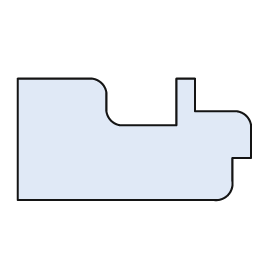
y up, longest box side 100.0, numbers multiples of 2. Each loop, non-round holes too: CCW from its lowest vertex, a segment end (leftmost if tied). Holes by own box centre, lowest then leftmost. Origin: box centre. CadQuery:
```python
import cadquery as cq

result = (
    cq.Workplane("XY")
    .moveTo(-50.0, -26.0)
    .lineTo(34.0, -26.0)
    .threePointArc((40.0, -24.0), (42.0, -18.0))
    .lineTo(42.0, -8.0)
    .lineTo(50.0, -8.0)
    .lineTo(50.0, 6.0)
    .threePointArc((48.0, 10.0), (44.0, 12.0))
    .lineTo(26.0, 12.0)
    .lineTo(26.0, 26.0)
    .lineTo(18.0, 26.0)
    .lineTo(18.0, 6.0)
    .lineTo(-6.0, 6.0)
    .threePointArc((-10.0, 8.0), (-12.0, 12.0))
    .lineTo(-12.0, 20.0)
    .threePointArc((-14.0, 24.0), (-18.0, 26.0))
    .lineTo(-50.0, 26.0)
    .close()
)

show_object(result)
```